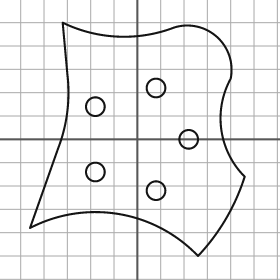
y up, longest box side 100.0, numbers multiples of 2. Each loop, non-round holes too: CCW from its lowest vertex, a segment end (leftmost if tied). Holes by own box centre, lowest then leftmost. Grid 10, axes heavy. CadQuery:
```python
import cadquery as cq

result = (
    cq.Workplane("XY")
    .moveTo(26.0, -50.0)
    .threePointArc((38.0, -34.0), (46.0, -16.0))
    .threePointArc((36.0, 4.0), (40.0, 26.0))
    .threePointArc((34.0, 44.0), (16.0, 48.0))
    .threePointArc((-8.0, 44.0), (-32.0, 50.0))
    .lineTo(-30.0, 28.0)
    .threePointArc((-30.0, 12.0), (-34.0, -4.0))
    .lineTo(-46.0, -38.0)
    .threePointArc((-8.0, -32.0), (26.0, -50.0))
    .close()
    .moveTo(8.0, -22.0)
    .circle(4.0)
    .moveTo(-18.0, -14.0)
    .circle(4.0)
    .moveTo(22.0, 0.0)
    .circle(4.0)
    .moveTo(-18.0, 14.0)
    .circle(4.0)
    .moveTo(8.0, 22.0)
    .circle(4.0)
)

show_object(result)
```